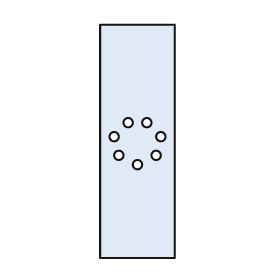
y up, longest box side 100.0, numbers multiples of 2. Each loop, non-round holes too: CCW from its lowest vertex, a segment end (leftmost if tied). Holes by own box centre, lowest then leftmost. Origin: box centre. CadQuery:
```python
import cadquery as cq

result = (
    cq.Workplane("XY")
    .moveTo(-16.0, -50.0)
    .lineTo(16.0, -50.0)
    .lineTo(16.0, 50.0)
    .lineTo(-16.0, 50.0)
    .close()
    .moveTo(0.0, -10.0)
    .circle(2.0)
    .moveTo(-8.0, -6.0)
    .circle(2.0)
    .moveTo(8.0, -6.0)
    .circle(2.0)
    .moveTo(-10.0, 2.0)
    .circle(2.0)
    .moveTo(10.0, 2.0)
    .circle(2.0)
    .moveTo(-4.0, 8.0)
    .circle(2.0)
    .moveTo(4.0, 8.0)
    .circle(2.0)
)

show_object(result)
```